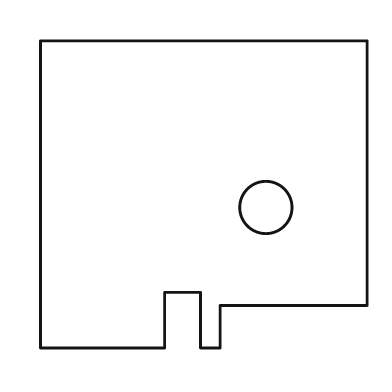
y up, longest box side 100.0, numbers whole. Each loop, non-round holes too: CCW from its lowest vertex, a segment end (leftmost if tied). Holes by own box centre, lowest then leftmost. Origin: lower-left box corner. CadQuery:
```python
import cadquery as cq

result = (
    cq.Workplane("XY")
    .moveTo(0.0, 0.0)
    .lineTo(38.0, 0.0)
    .lineTo(38.0, 17.0)
    .lineTo(49.0, 17.0)
    .lineTo(49.0, 0.0)
    .lineTo(55.0, 0.0)
    .lineTo(55.0, 13.0)
    .lineTo(100.0, 13.0)
    .lineTo(100.0, 94.0)
    .lineTo(0.0, 94.0)
    .close()
    .moveTo(69.0, 43.0)
    .circle(8.0)
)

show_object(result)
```